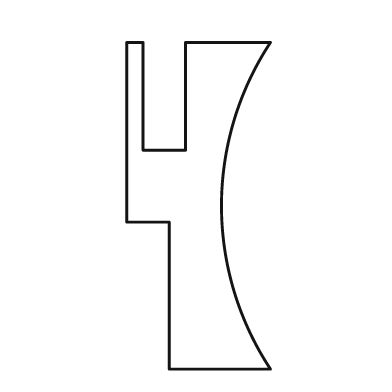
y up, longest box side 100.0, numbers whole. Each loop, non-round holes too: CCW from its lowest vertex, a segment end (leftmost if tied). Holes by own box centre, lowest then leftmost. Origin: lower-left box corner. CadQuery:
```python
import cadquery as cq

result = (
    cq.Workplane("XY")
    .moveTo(13.0, 0.0)
    .lineTo(44.0, 0.0)
    .threePointArc((29.0, 50.0), (44.0, 100.0))
    .lineTo(18.0, 100.0)
    .lineTo(18.0, 67.0)
    .lineTo(5.0, 67.0)
    .lineTo(5.0, 100.0)
    .lineTo(0.0, 100.0)
    .lineTo(0.0, 45.0)
    .lineTo(13.0, 45.0)
    .close()
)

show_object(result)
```